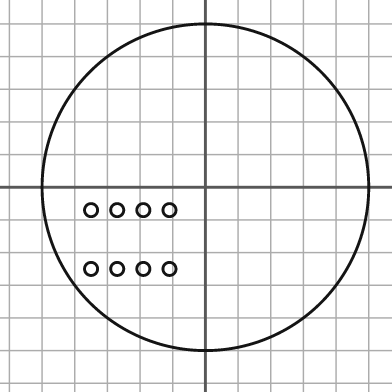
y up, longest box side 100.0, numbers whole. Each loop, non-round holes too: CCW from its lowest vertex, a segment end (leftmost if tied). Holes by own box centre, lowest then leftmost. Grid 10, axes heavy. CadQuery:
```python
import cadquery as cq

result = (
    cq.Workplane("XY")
    .moveTo(0.0, 0.0)
    .circle(50.0)
    .moveTo(-35.0, -25.0)
    .circle(2.0)
    .moveTo(-27.0, -25.0)
    .circle(2.0)
    .moveTo(-19.0, -25.0)
    .circle(2.0)
    .moveTo(-11.0, -25.0)
    .circle(2.0)
    .moveTo(-35.0, -7.0)
    .circle(2.0)
    .moveTo(-27.0, -7.0)
    .circle(2.0)
    .moveTo(-19.0, -7.0)
    .circle(2.0)
    .moveTo(-11.0, -7.0)
    .circle(2.0)
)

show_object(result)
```